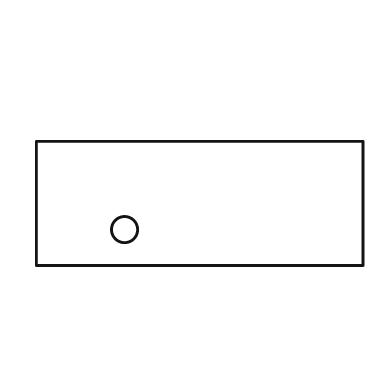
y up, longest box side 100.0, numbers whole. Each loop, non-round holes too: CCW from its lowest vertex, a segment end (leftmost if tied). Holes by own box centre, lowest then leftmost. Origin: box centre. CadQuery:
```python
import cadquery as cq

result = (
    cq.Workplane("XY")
    .moveTo(-50.0, -19.0)
    .lineTo(50.0, -19.0)
    .lineTo(50.0, 19.0)
    .lineTo(-50.0, 19.0)
    .close()
    .moveTo(-23.0, -8.0)
    .circle(4.0)
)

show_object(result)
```